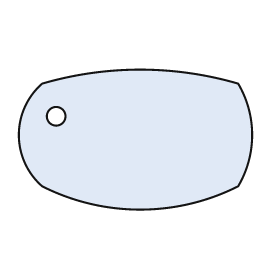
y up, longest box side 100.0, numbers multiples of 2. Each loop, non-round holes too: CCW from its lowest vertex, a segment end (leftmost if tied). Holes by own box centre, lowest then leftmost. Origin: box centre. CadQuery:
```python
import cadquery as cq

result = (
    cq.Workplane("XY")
    .moveTo(-40.0, -20.0)
    .threePointArc((2.0, -30.0), (44.0, -20.0))
    .threePointArc((50.0, 2.0), (44.0, 24.0))
    .threePointArc((2.0, 30.0), (-40.0, 24.0))
    .threePointArc((-50.0, 2.0), (-40.0, -20.0))
    .close()
    .moveTo(-34.0, 10.0)
    .circle(4.0)
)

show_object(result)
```